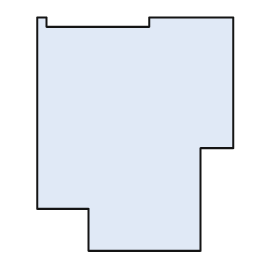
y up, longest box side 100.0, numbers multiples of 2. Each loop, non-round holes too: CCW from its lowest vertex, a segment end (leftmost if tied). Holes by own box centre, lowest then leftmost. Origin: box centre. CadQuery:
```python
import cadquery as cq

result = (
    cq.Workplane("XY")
    .moveTo(-20.0, -50.0)
    .lineTo(28.0, -50.0)
    .lineTo(28.0, -6.0)
    .lineTo(42.0, -6.0)
    .lineTo(42.0, 50.0)
    .lineTo(6.0, 50.0)
    .lineTo(6.0, 46.0)
    .lineTo(-38.0, 46.0)
    .lineTo(-38.0, 50.0)
    .lineTo(-42.0, 50.0)
    .lineTo(-42.0, -32.0)
    .lineTo(-20.0, -32.0)
    .close()
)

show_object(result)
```